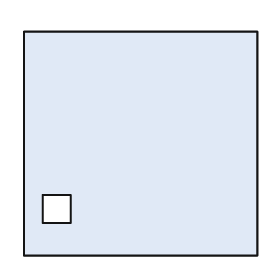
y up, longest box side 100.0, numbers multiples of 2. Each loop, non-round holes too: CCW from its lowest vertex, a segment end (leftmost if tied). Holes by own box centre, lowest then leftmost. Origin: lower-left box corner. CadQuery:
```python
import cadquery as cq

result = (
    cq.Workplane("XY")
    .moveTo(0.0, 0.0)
    .lineTo(100.0, 0.0)
    .lineTo(100.0, 96.0)
    .lineTo(0.0, 96.0)
    .close()
    .moveTo(8.0, 14.0)
    .lineTo(20.0, 14.0)
    .lineTo(20.0, 26.0)
    .lineTo(8.0, 26.0)
    .close()
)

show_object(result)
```